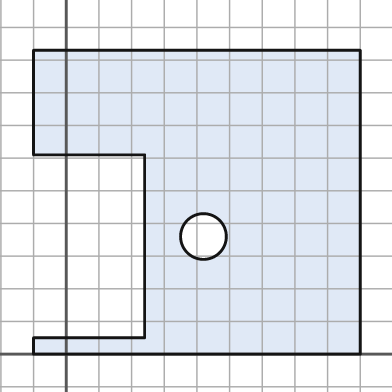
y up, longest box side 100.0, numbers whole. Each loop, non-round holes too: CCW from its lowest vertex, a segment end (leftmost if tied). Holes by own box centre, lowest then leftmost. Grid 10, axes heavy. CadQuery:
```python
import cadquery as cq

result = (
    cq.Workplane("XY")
    .moveTo(-10.0, 0.0)
    .lineTo(90.0, 0.0)
    .lineTo(90.0, 93.0)
    .lineTo(-10.0, 93.0)
    .lineTo(-10.0, 61.0)
    .lineTo(24.0, 61.0)
    .lineTo(24.0, 5.0)
    .lineTo(-10.0, 5.0)
    .close()
    .moveTo(42.0, 36.0)
    .circle(7.0)
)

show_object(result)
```